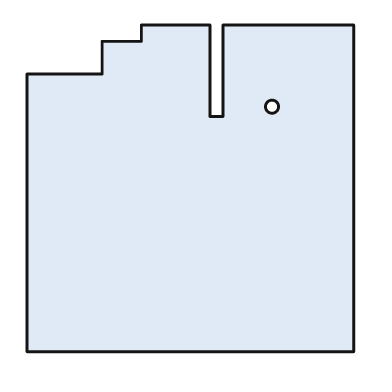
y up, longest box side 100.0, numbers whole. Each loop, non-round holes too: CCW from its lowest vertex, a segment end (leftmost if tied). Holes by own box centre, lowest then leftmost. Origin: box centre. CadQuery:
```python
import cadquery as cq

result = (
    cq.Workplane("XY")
    .moveTo(-50.0, -50.0)
    .lineTo(50.0, -50.0)
    .lineTo(50.0, 50.0)
    .lineTo(10.0, 50.0)
    .lineTo(10.0, 22.0)
    .lineTo(6.0, 22.0)
    .lineTo(6.0, 50.0)
    .lineTo(-15.0, 50.0)
    .lineTo(-15.0, 45.0)
    .lineTo(-27.0, 45.0)
    .lineTo(-27.0, 35.0)
    .lineTo(-50.0, 35.0)
    .close()
    .moveTo(25.0, 25.0)
    .circle(2.0)
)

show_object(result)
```